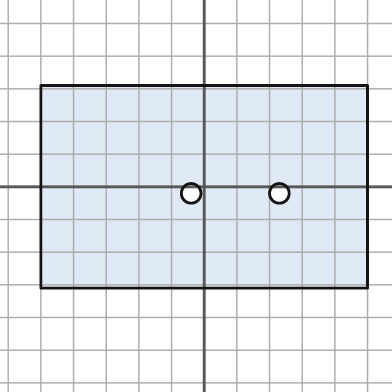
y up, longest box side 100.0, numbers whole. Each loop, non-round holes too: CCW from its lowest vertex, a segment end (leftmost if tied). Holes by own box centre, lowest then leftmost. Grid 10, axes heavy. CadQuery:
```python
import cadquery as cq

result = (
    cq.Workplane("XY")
    .moveTo(-50.0, -31.0)
    .lineTo(50.0, -31.0)
    .lineTo(50.0, 31.0)
    .lineTo(-50.0, 31.0)
    .close()
    .moveTo(-4.0, -2.0)
    .circle(3.0)
    .moveTo(23.0, -2.0)
    .circle(3.0)
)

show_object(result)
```